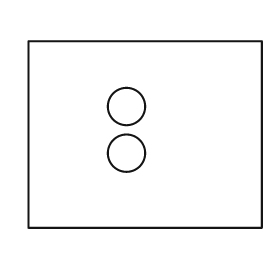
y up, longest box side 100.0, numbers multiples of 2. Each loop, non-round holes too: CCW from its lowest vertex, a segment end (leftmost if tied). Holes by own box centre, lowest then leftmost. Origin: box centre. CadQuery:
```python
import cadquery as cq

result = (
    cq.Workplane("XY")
    .moveTo(-50.0, -40.0)
    .lineTo(50.0, -40.0)
    .lineTo(50.0, 40.0)
    .lineTo(-50.0, 40.0)
    .close()
    .moveTo(-8.0, -8.0)
    .circle(8.0)
    .moveTo(-8.0, 12.0)
    .circle(8.0)
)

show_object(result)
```